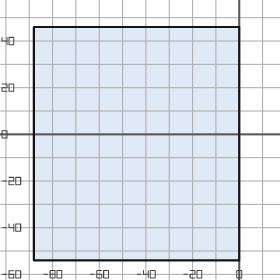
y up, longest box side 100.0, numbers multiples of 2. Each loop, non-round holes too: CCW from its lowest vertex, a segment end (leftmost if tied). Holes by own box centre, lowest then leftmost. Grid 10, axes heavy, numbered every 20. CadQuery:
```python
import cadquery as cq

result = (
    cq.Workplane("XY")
    .moveTo(-88.0, -54.0)
    .lineTo(0.0, -54.0)
    .lineTo(0.0, 46.0)
    .lineTo(-88.0, 46.0)
    .close()
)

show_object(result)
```